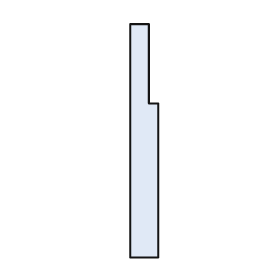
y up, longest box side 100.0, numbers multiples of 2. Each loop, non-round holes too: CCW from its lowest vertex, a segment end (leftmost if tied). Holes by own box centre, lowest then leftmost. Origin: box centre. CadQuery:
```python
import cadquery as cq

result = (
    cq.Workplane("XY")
    .moveTo(-6.0, -50.0)
    .lineTo(6.0, -50.0)
    .lineTo(6.0, 16.0)
    .lineTo(2.0, 16.0)
    .lineTo(2.0, 50.0)
    .lineTo(-6.0, 50.0)
    .close()
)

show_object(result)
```